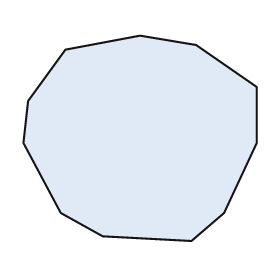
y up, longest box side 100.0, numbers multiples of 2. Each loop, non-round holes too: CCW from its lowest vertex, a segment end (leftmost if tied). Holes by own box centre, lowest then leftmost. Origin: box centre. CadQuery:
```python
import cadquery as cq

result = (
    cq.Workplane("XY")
    .moveTo(22.0, -44.0)
    .lineTo(36.0, -32.0)
    .lineTo(50.0, -2.0)
    .lineTo(50.0, 22.0)
    .lineTo(24.0, 40.0)
    .lineTo(0.0, 44.0)
    .lineTo(-32.0, 38.0)
    .lineTo(-48.0, 16.0)
    .lineTo(-50.0, -2.0)
    .lineTo(-34.0, -32.0)
    .lineTo(-16.0, -42.0)
    .close()
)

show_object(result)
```